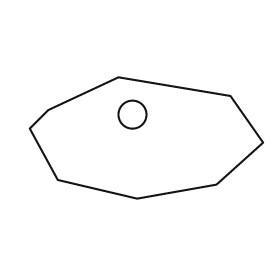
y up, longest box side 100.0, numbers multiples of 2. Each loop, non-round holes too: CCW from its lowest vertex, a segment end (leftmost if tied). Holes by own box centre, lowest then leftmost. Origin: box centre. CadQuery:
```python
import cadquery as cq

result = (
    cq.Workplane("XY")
    .moveTo(-4.0, -26.0)
    .lineTo(30.0, -20.0)
    .lineTo(50.0, -2.0)
    .lineTo(36.0, 18.0)
    .lineTo(-12.0, 26.0)
    .lineTo(-42.0, 12.0)
    .lineTo(-50.0, 4.0)
    .lineTo(-38.0, -18.0)
    .close()
    .moveTo(-6.0, 10.0)
    .circle(6.0)
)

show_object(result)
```